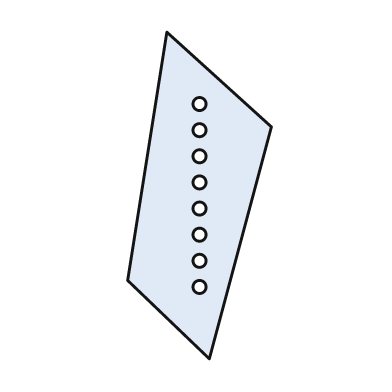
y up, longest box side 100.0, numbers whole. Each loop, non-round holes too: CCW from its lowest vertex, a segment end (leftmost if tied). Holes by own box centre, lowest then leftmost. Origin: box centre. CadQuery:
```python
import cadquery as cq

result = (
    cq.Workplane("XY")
    .moveTo(3.0, -50.0)
    .lineTo(22.0, 21.0)
    .lineTo(-10.0, 50.0)
    .lineTo(-22.0, -26.0)
    .close()
    .moveTo(0.0, -28.0)
    .circle(2.0)
    .moveTo(0.0, -20.0)
    .circle(2.0)
    .moveTo(0.0, -12.0)
    .circle(2.0)
    .moveTo(0.0, -4.0)
    .circle(2.0)
    .moveTo(0.0, 4.0)
    .circle(2.0)
    .moveTo(0.0, 12.0)
    .circle(2.0)
    .moveTo(0.0, 20.0)
    .circle(2.0)
    .moveTo(0.0, 28.0)
    .circle(2.0)
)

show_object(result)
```